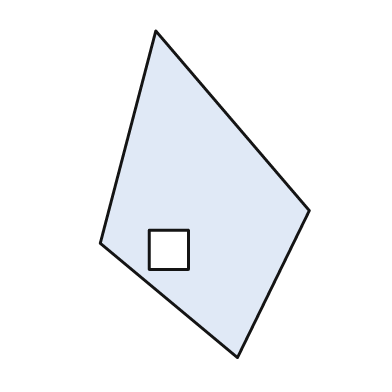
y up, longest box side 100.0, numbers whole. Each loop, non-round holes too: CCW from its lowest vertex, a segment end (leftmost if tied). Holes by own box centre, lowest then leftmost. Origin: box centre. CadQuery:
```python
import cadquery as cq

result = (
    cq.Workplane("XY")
    .moveTo(10.0, -50.0)
    .lineTo(32.0, -5.0)
    .lineTo(-15.0, 50.0)
    .lineTo(-32.0, -15.0)
    .close()
    .moveTo(-17.0, -23.0)
    .lineTo(-5.0, -23.0)
    .lineTo(-5.0, -11.0)
    .lineTo(-17.0, -11.0)
    .close()
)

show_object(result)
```